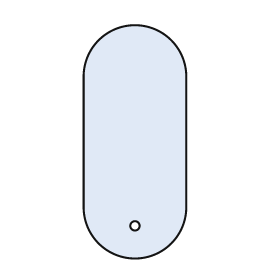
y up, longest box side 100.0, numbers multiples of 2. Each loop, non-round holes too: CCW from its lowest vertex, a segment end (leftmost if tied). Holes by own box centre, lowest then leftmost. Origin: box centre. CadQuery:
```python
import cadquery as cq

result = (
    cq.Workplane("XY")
    .moveTo(-22.0, -28.0)
    .threePointArc((0.0, -50.0), (22.0, -28.0))
    .lineTo(22.0, 28.0)
    .threePointArc((0.0, 50.0), (-22.0, 28.0))
    .close()
    .moveTo(0.0, -36.0)
    .circle(2.0)
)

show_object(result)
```